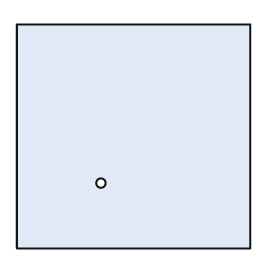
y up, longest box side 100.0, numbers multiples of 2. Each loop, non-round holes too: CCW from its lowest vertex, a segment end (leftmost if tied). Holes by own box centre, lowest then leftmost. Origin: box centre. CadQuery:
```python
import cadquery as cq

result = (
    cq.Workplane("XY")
    .moveTo(-50.0, -48.0)
    .lineTo(50.0, -48.0)
    .lineTo(50.0, 48.0)
    .lineTo(-50.0, 48.0)
    .close()
    .moveTo(-14.0, -20.0)
    .circle(2.0)
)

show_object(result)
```